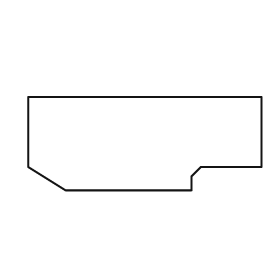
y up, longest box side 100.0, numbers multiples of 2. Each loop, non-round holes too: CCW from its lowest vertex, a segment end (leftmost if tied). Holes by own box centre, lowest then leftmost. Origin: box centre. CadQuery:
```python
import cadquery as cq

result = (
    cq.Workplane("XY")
    .moveTo(-34.0, -20.0)
    .lineTo(20.0, -20.0)
    .lineTo(20.0, -14.0)
    .lineTo(24.0, -10.0)
    .lineTo(50.0, -10.0)
    .lineTo(50.0, 20.0)
    .lineTo(-50.0, 20.0)
    .lineTo(-50.0, -10.0)
    .close()
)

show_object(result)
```